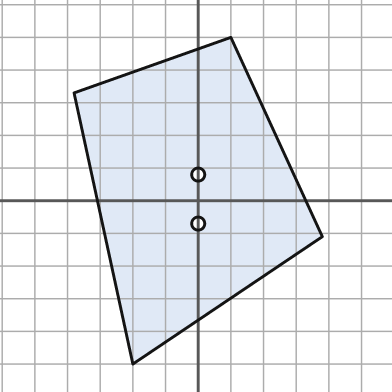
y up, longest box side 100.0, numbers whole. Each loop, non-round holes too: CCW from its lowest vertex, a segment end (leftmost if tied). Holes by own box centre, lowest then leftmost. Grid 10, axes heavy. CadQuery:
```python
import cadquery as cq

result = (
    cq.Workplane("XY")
    .moveTo(-20.0, -50.0)
    .lineTo(38.0, -11.0)
    .lineTo(10.0, 50.0)
    .lineTo(-38.0, 33.0)
    .close()
    .moveTo(0.0, -7.0)
    .circle(2.0)
    .moveTo(0.0, 8.0)
    .circle(2.0)
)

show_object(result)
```